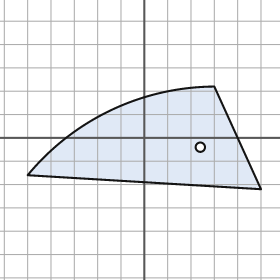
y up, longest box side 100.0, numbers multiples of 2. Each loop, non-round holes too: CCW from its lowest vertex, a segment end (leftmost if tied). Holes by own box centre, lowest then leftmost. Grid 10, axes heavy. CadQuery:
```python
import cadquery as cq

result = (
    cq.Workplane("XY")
    .moveTo(50.0, -22.0)
    .lineTo(30.0, 22.0)
    .threePointArc((-14.0, 12.0), (-50.0, -16.0))
    .close()
    .moveTo(24.0, -4.0)
    .circle(2.0)
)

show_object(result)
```